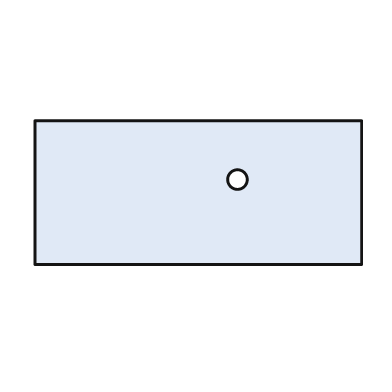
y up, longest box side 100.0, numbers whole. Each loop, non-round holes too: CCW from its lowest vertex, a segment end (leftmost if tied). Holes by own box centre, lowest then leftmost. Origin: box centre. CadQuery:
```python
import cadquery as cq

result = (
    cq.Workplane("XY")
    .moveTo(-50.0, -22.0)
    .lineTo(50.0, -22.0)
    .lineTo(50.0, 22.0)
    .lineTo(-50.0, 22.0)
    .close()
    .moveTo(12.0, 4.0)
    .circle(3.0)
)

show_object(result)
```